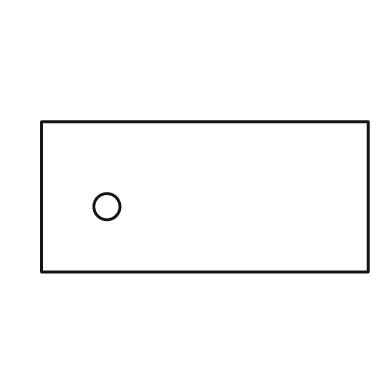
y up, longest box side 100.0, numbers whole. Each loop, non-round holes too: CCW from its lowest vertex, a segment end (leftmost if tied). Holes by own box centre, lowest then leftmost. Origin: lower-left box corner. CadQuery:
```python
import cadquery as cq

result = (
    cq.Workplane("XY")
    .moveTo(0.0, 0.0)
    .lineTo(100.0, 0.0)
    .lineTo(100.0, 46.0)
    .lineTo(0.0, 46.0)
    .close()
    .moveTo(20.0, 20.0)
    .circle(4.0)
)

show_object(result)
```